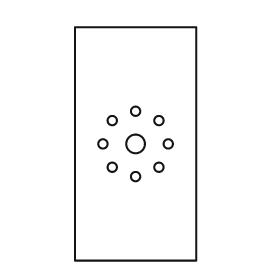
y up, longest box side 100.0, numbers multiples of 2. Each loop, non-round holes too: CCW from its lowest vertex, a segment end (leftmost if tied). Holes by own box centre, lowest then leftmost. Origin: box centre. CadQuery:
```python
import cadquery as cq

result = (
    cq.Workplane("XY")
    .moveTo(-26.0, -50.0)
    .lineTo(26.0, -50.0)
    .lineTo(26.0, 50.0)
    .lineTo(-26.0, 50.0)
    .close()
    .moveTo(0.0, -14.0)
    .circle(2.0)
    .moveTo(-10.0, -10.0)
    .circle(2.0)
    .moveTo(10.0, -10.0)
    .circle(2.0)
    .moveTo(-14.0, 0.0)
    .circle(2.0)
    .moveTo(0.0, 0.0)
    .circle(4.0)
    .moveTo(14.0, 0.0)
    .circle(2.0)
    .moveTo(-10.0, 10.0)
    .circle(2.0)
    .moveTo(10.0, 10.0)
    .circle(2.0)
    .moveTo(0.0, 14.0)
    .circle(2.0)
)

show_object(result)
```